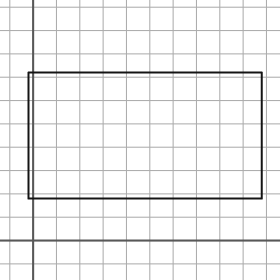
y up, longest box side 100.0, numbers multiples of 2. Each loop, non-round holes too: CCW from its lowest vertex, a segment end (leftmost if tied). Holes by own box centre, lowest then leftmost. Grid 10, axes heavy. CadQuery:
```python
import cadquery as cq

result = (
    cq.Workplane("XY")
    .moveTo(-2.0, 18.0)
    .lineTo(98.0, 18.0)
    .lineTo(98.0, 72.0)
    .lineTo(-2.0, 72.0)
    .close()
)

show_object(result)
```